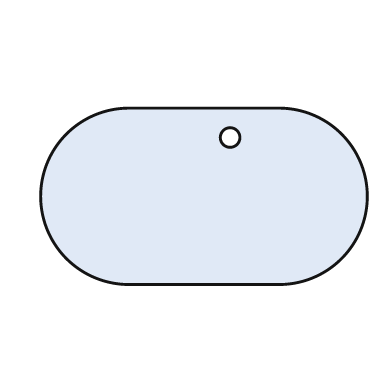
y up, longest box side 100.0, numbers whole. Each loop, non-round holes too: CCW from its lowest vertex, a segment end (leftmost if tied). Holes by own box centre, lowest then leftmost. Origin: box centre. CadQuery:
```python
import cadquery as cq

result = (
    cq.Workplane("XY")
    .moveTo(-23.0, -27.0)
    .lineTo(23.0, -27.0)
    .threePointArc((50.0, 0.0), (23.0, 27.0))
    .lineTo(-23.0, 27.0)
    .threePointArc((-50.0, 0.0), (-23.0, -27.0))
    .close()
    .moveTo(8.0, 18.0)
    .circle(3.0)
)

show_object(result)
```